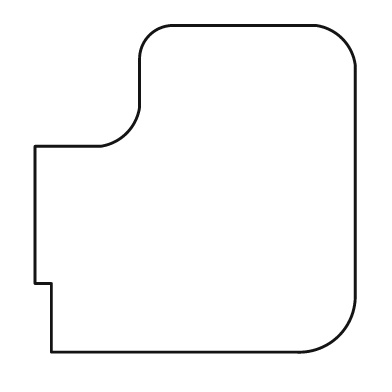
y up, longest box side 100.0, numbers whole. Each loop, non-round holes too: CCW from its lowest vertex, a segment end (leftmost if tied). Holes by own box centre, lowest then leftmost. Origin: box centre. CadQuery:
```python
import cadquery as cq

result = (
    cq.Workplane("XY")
    .moveTo(-44.0, -50.0)
    .lineTo(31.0, -50.0)
    .threePointArc((44.0, -45.0), (49.0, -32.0))
    .lineTo(49.0, 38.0)
    .threePointArc((45.0, 46.0), (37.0, 50.0))
    .lineTo(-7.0, 50.0)
    .threePointArc((-14.0, 47.0), (-17.0, 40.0))
    .lineTo(-17.0, 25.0)
    .threePointArc((-21.0, 17.0), (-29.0, 13.0))
    .lineTo(-49.0, 13.0)
    .lineTo(-49.0, -29.0)
    .lineTo(-44.0, -29.0)
    .close()
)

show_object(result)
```